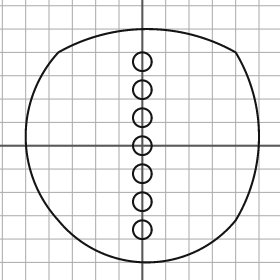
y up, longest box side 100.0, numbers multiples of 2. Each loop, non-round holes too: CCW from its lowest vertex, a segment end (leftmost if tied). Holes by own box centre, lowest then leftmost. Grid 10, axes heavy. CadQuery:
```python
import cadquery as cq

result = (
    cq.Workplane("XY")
    .moveTo(-36.0, -32.0)
    .threePointArc((2.0, -50.0), (40.0, -32.0))
    .threePointArc((50.0, 4.0), (40.0, 40.0))
    .threePointArc((2.0, 50.0), (-36.0, 40.0))
    .threePointArc((-50.0, 4.0), (-36.0, -32.0))
    .close()
    .moveTo(0.0, -36.0)
    .circle(4.0)
    .moveTo(0.0, -24.0)
    .circle(4.0)
    .moveTo(0.0, -12.0)
    .circle(4.0)
    .moveTo(0.0, 0.0)
    .circle(4.0)
    .moveTo(0.0, 12.0)
    .circle(4.0)
    .moveTo(0.0, 24.0)
    .circle(4.0)
    .moveTo(0.0, 36.0)
    .circle(4.0)
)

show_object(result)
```